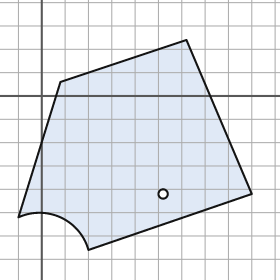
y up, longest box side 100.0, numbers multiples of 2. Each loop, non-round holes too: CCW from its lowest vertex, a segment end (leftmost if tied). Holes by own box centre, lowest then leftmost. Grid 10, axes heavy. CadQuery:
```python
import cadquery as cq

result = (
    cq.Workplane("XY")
    .moveTo(20.0, -66.0)
    .lineTo(90.0, -42.0)
    .lineTo(62.0, 24.0)
    .lineTo(8.0, 6.0)
    .lineTo(-10.0, -52.0)
    .threePointArc((8.0, -52.0), (20.0, -66.0))
    .close()
    .moveTo(52.0, -42.0)
    .circle(2.0)
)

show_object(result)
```